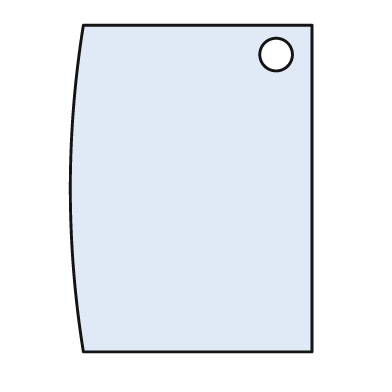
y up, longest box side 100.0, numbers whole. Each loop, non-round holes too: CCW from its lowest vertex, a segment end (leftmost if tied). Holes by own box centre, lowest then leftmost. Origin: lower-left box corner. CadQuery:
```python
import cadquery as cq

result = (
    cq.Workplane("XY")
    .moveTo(4.0, 0.0)
    .lineTo(74.0, 0.0)
    .lineTo(74.0, 100.0)
    .lineTo(4.0, 100.0)
    .threePointArc((0.0, 50.0), (4.0, 0.0))
    .close()
    .moveTo(63.0, 91.0)
    .circle(5.0)
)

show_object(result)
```